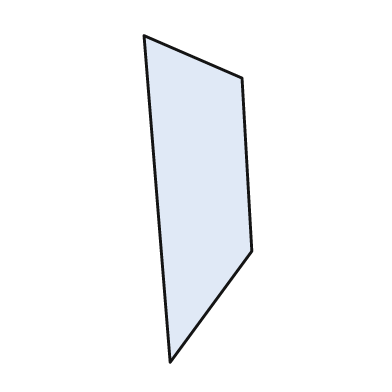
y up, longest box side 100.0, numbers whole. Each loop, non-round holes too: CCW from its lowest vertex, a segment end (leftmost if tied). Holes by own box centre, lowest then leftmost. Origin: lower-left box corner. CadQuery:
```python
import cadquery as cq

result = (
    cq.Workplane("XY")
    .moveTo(8.0, 0.0)
    .lineTo(33.0, 34.0)
    .lineTo(30.0, 87.0)
    .lineTo(0.0, 100.0)
    .close()
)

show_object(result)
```